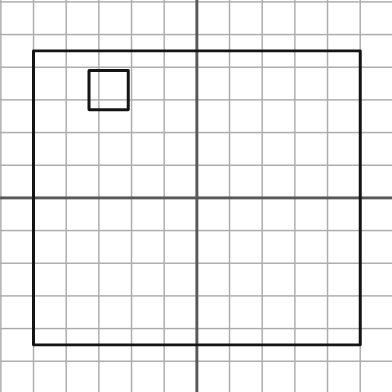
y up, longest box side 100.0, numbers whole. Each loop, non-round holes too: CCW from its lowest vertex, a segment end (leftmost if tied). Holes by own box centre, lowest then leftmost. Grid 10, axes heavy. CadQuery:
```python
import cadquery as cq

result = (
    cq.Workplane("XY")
    .moveTo(-50.0, -45.0)
    .lineTo(50.0, -45.0)
    .lineTo(50.0, 45.0)
    .lineTo(-50.0, 45.0)
    .close()
    .moveTo(-33.0, 27.0)
    .lineTo(-21.0, 27.0)
    .lineTo(-21.0, 39.0)
    .lineTo(-33.0, 39.0)
    .close()
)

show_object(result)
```